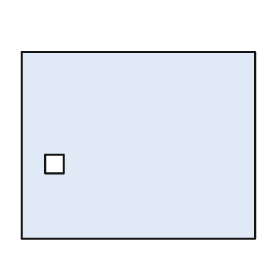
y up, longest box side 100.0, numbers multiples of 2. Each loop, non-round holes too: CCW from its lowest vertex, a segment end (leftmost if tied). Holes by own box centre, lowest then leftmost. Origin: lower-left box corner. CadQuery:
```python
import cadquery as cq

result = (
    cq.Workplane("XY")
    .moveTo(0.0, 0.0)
    .lineTo(100.0, 0.0)
    .lineTo(100.0, 80.0)
    .lineTo(0.0, 80.0)
    .close()
    .moveTo(10.0, 28.0)
    .lineTo(18.0, 28.0)
    .lineTo(18.0, 36.0)
    .lineTo(10.0, 36.0)
    .close()
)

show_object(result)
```